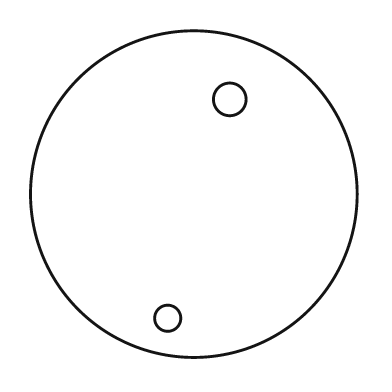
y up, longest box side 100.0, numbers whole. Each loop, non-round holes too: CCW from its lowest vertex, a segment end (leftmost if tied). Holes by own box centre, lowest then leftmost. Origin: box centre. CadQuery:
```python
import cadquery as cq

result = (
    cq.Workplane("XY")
    .moveTo(0.0, 0.0)
    .circle(50.0)
    .moveTo(-8.0, -38.0)
    .circle(4.0)
    .moveTo(11.0, 29.0)
    .circle(5.0)
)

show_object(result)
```